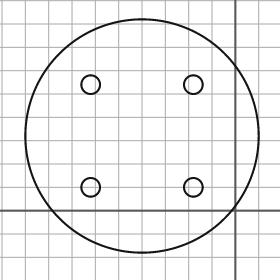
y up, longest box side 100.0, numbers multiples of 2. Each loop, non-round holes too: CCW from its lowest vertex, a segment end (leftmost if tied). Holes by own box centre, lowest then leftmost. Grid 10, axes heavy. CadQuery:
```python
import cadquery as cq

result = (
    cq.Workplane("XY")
    .moveTo(-40.0, 32.0)
    .circle(50.0)
    .moveTo(-62.0, 10.0)
    .circle(4.0)
    .moveTo(-18.0, 10.0)
    .circle(4.0)
    .moveTo(-62.0, 54.0)
    .circle(4.0)
    .moveTo(-18.0, 54.0)
    .circle(4.0)
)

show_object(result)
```